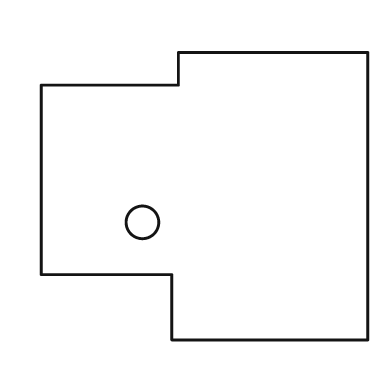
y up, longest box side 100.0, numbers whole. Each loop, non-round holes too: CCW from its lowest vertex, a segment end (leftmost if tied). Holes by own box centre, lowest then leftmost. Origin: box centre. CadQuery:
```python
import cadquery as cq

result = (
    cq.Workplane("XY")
    .moveTo(-10.0, -44.0)
    .lineTo(50.0, -44.0)
    .lineTo(50.0, 44.0)
    .lineTo(-8.0, 44.0)
    .lineTo(-8.0, 34.0)
    .lineTo(-50.0, 34.0)
    .lineTo(-50.0, -24.0)
    .lineTo(-10.0, -24.0)
    .close()
    .moveTo(-19.0, -8.0)
    .circle(5.0)
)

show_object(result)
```